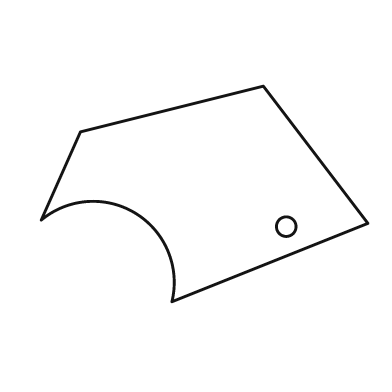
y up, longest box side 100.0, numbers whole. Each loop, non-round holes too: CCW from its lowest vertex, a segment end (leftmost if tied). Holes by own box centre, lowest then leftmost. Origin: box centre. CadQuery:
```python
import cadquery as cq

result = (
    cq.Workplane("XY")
    .moveTo(-10.0, -33.0)
    .lineTo(50.0, -9.0)
    .lineTo(18.0, 33.0)
    .lineTo(-38.0, 19.0)
    .lineTo(-50.0, -8.0)
    .threePointArc((-21.0, -6.0), (-10.0, -33.0))
    .close()
    .moveTo(25.0, -10.0)
    .circle(3.0)
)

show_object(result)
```